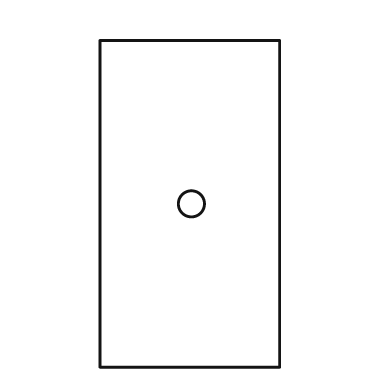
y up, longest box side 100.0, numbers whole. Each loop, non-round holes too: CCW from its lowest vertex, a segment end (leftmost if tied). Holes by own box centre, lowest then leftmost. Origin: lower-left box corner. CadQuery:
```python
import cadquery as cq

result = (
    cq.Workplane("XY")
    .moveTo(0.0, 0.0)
    .lineTo(55.0, 0.0)
    .lineTo(55.0, 100.0)
    .lineTo(0.0, 100.0)
    .close()
    .moveTo(28.0, 50.0)
    .circle(4.0)
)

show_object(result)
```